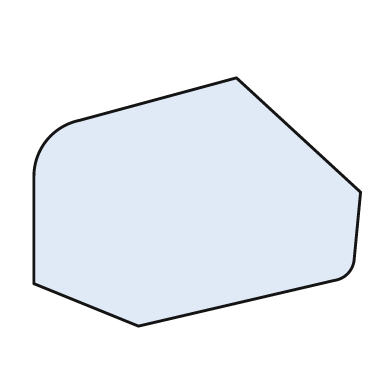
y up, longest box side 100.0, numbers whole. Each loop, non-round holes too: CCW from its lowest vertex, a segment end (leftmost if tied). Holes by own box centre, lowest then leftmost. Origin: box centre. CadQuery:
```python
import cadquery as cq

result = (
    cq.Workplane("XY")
    .moveTo(-18.0, -38.0)
    .lineTo(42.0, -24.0)
    .threePointArc((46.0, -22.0), (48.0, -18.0))
    .lineTo(50.0, 3.0)
    .lineTo(12.0, 38.0)
    .lineTo(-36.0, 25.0)
    .threePointArc((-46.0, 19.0), (-50.0, 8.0))
    .lineTo(-50.0, -25.0)
    .close()
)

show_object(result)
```